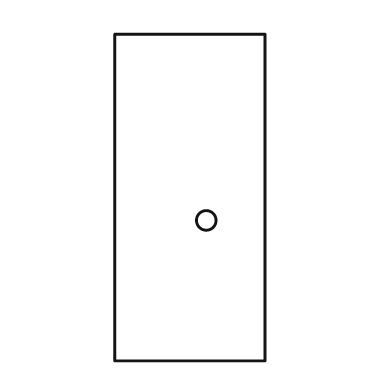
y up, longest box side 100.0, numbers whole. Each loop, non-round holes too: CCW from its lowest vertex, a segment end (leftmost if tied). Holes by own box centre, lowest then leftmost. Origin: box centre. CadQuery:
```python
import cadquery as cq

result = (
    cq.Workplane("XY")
    .moveTo(-23.0, -50.0)
    .lineTo(23.0, -50.0)
    .lineTo(23.0, 50.0)
    .lineTo(-23.0, 50.0)
    .close()
    .moveTo(5.0, -7.0)
    .circle(3.0)
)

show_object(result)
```